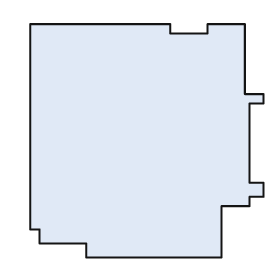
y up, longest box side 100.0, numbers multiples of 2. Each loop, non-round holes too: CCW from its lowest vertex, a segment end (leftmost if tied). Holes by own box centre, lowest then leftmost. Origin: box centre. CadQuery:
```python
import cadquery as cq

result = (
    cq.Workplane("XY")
    .moveTo(-26.0, -50.0)
    .lineTo(32.0, -50.0)
    .lineTo(32.0, -28.0)
    .lineTo(44.0, -28.0)
    .lineTo(44.0, -24.0)
    .lineTo(50.0, -24.0)
    .lineTo(50.0, -18.0)
    .lineTo(44.0, -18.0)
    .lineTo(44.0, 16.0)
    .lineTo(50.0, 16.0)
    .lineTo(50.0, 20.0)
    .lineTo(42.0, 20.0)
    .lineTo(42.0, 50.0)
    .lineTo(26.0, 50.0)
    .lineTo(26.0, 46.0)
    .lineTo(10.0, 46.0)
    .lineTo(10.0, 50.0)
    .lineTo(-50.0, 50.0)
    .lineTo(-50.0, -38.0)
    .lineTo(-46.0, -38.0)
    .lineTo(-46.0, -44.0)
    .lineTo(-26.0, -44.0)
    .close()
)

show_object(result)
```